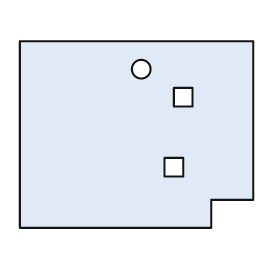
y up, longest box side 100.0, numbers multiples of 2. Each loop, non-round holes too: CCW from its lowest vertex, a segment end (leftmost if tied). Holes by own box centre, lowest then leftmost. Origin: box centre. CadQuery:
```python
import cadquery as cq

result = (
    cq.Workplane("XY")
    .moveTo(-50.0, -40.0)
    .lineTo(32.0, -40.0)
    .lineTo(32.0, -28.0)
    .lineTo(50.0, -28.0)
    .lineTo(50.0, 40.0)
    .lineTo(-50.0, 40.0)
    .close()
    .moveTo(12.0, -18.0)
    .lineTo(20.0, -18.0)
    .lineTo(20.0, -10.0)
    .lineTo(12.0, -10.0)
    .close()
    .moveTo(16.0, 12.0)
    .lineTo(24.0, 12.0)
    .lineTo(24.0, 20.0)
    .lineTo(16.0, 20.0)
    .close()
    .moveTo(2.0, 28.0)
    .circle(4.0)
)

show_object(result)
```